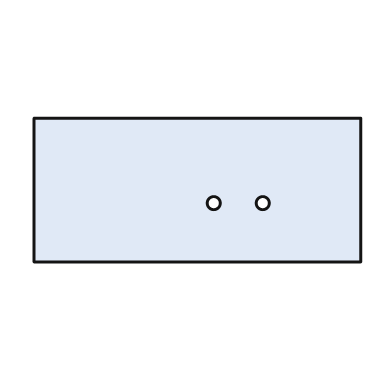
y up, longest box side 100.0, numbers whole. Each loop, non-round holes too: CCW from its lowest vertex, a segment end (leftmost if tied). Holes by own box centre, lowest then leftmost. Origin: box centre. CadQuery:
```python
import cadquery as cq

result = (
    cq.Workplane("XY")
    .moveTo(-50.0, -22.0)
    .lineTo(50.0, -22.0)
    .lineTo(50.0, 22.0)
    .lineTo(-50.0, 22.0)
    .close()
    .moveTo(5.0, -4.0)
    .circle(2.0)
    .moveTo(20.0, -4.0)
    .circle(2.0)
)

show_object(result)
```